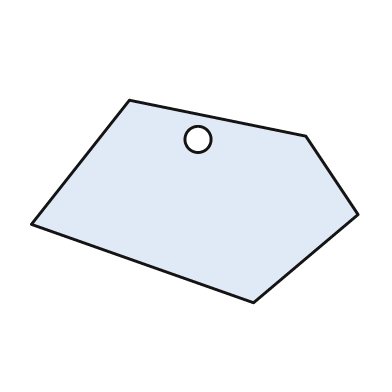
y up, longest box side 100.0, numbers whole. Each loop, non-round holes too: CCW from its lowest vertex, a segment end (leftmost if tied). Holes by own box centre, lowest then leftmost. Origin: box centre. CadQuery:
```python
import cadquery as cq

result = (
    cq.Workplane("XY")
    .moveTo(18.0, -31.0)
    .lineTo(50.0, -4.0)
    .lineTo(34.0, 20.0)
    .lineTo(-20.0, 31.0)
    .lineTo(-50.0, -7.0)
    .close()
    .moveTo(1.0, 19.0)
    .circle(4.0)
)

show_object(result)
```